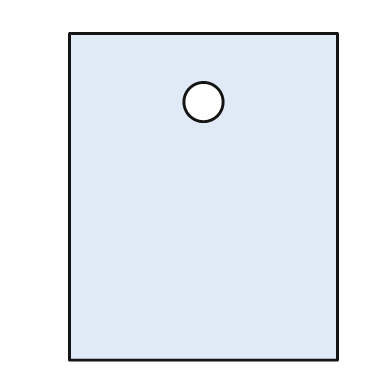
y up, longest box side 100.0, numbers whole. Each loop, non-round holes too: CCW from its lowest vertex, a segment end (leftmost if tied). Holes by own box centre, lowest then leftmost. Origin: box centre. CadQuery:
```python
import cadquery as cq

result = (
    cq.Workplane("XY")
    .moveTo(-41.0, -50.0)
    .lineTo(41.0, -50.0)
    .lineTo(41.0, 50.0)
    .lineTo(-41.0, 50.0)
    .close()
    .moveTo(0.0, 29.0)
    .circle(6.0)
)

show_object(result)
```